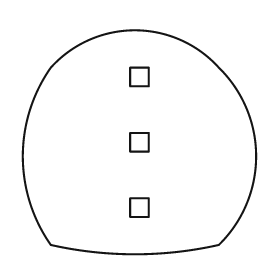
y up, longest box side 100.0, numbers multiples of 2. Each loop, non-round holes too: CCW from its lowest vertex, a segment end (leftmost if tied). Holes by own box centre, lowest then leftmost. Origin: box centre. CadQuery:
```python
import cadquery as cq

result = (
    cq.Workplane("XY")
    .moveTo(-38.0, -44.0)
    .threePointArc((-2.0, -48.0), (34.0, -44.0))
    .threePointArc((50.0, -6.0), (34.0, 32.0))
    .threePointArc((-2.0, 48.0), (-38.0, 32.0))
    .threePointArc((-50.0, -6.0), (-38.0, -44.0))
    .close()
    .moveTo(-4.0, -32.0)
    .lineTo(4.0, -32.0)
    .lineTo(4.0, -24.0)
    .lineTo(-4.0, -24.0)
    .close()
    .moveTo(-4.0, -4.0)
    .lineTo(4.0, -4.0)
    .lineTo(4.0, 4.0)
    .lineTo(-4.0, 4.0)
    .close()
    .moveTo(-4.0, 24.0)
    .lineTo(4.0, 24.0)
    .lineTo(4.0, 32.0)
    .lineTo(-4.0, 32.0)
    .close()
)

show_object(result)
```